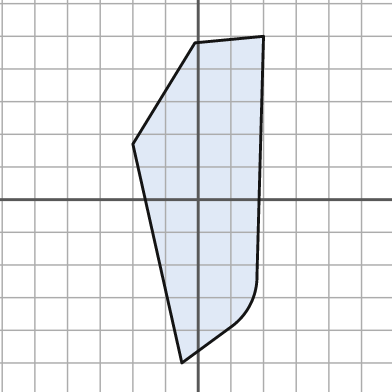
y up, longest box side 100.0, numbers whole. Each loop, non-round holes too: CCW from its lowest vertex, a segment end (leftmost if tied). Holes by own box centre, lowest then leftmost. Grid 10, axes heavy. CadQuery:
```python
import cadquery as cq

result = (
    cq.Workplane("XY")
    .moveTo(-5.0, -50.0)
    .lineTo(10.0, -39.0)
    .threePointArc((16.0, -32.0), (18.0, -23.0))
    .lineTo(20.0, 50.0)
    .lineTo(-1.0, 48.0)
    .lineTo(-20.0, 17.0)
    .close()
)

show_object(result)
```